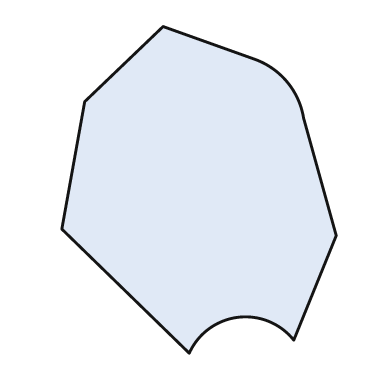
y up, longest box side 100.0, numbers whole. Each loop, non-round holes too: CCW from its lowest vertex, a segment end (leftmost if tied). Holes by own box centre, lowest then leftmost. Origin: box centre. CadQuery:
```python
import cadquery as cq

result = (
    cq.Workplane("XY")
    .moveTo(-3.0, -50.0)
    .threePointArc((12.0, -39.0), (29.0, -46.0))
    .lineTo(42.0, -14.0)
    .lineTo(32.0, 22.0)
    .threePointArc((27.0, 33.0), (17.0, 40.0))
    .lineTo(-11.0, 50.0)
    .lineTo(-35.0, 27.0)
    .lineTo(-42.0, -12.0)
    .close()
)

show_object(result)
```